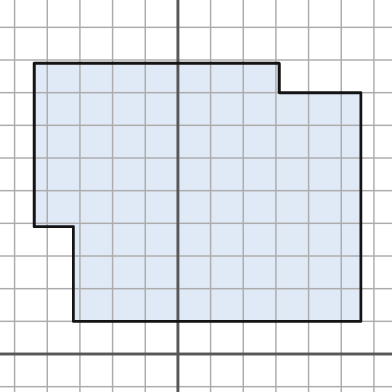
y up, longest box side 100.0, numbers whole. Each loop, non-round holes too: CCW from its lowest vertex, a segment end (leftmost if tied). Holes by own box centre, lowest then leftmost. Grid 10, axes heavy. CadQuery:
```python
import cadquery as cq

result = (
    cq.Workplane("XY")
    .moveTo(-32.0, 10.0)
    .lineTo(56.0, 10.0)
    .lineTo(56.0, 80.0)
    .lineTo(31.0, 80.0)
    .lineTo(31.0, 89.0)
    .lineTo(-44.0, 89.0)
    .lineTo(-44.0, 39.0)
    .lineTo(-32.0, 39.0)
    .close()
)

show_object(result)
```